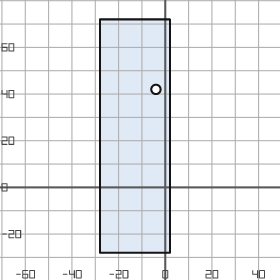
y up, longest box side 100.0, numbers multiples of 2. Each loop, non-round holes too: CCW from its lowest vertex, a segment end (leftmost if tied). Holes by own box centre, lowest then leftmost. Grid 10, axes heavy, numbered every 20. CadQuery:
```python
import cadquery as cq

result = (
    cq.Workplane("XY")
    .moveTo(-28.0, -28.0)
    .lineTo(2.0, -28.0)
    .lineTo(2.0, 72.0)
    .lineTo(-28.0, 72.0)
    .close()
    .moveTo(-4.0, 42.0)
    .circle(2.0)
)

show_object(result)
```